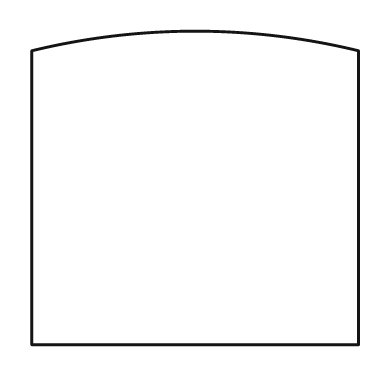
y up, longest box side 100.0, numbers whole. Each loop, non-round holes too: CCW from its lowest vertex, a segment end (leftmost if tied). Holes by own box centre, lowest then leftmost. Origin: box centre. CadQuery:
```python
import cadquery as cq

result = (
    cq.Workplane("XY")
    .moveTo(-50.0, -48.0)
    .lineTo(50.0, -48.0)
    .lineTo(50.0, 42.0)
    .threePointArc((0.0, 48.0), (-50.0, 42.0))
    .close()
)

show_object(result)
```